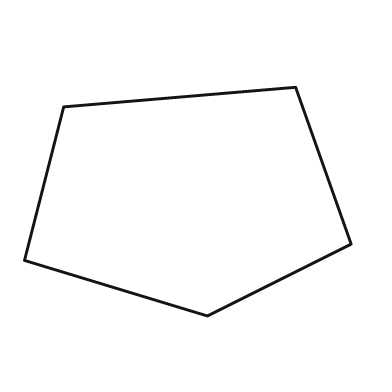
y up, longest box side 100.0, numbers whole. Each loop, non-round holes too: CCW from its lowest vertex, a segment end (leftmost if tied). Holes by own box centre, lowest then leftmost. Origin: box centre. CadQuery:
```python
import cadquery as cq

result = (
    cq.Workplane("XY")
    .moveTo(6.0, -35.0)
    .lineTo(50.0, -13.0)
    .lineTo(33.0, 35.0)
    .lineTo(-38.0, 29.0)
    .lineTo(-50.0, -18.0)
    .close()
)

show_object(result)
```